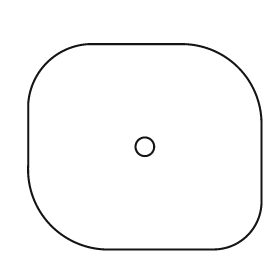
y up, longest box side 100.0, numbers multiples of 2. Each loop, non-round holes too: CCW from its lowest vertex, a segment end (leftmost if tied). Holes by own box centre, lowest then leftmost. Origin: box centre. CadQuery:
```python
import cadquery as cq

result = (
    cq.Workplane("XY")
    .moveTo(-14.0, -44.0)
    .lineTo(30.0, -44.0)
    .threePointArc((44.0, -38.0), (50.0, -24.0))
    .lineTo(50.0, 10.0)
    .threePointArc((40.0, 34.0), (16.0, 44.0))
    .lineTo(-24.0, 44.0)
    .threePointArc((-42.0, 36.0), (-50.0, 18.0))
    .lineTo(-50.0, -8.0)
    .threePointArc((-40.0, -34.0), (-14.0, -44.0))
    .close()
    .moveTo(0.0, 0.0)
    .circle(4.0)
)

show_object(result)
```